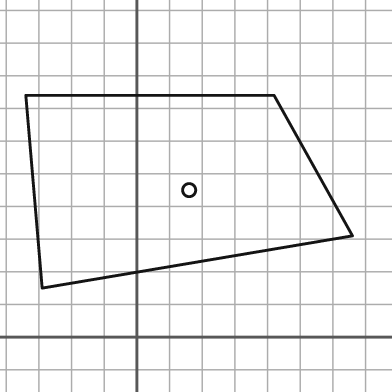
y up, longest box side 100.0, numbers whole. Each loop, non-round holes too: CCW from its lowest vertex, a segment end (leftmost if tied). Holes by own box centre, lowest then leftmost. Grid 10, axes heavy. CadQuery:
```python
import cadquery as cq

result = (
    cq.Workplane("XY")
    .moveTo(-29.0, 15.0)
    .lineTo(66.0, 31.0)
    .lineTo(42.0, 74.0)
    .lineTo(-34.0, 74.0)
    .close()
    .moveTo(16.0, 45.0)
    .circle(2.0)
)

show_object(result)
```